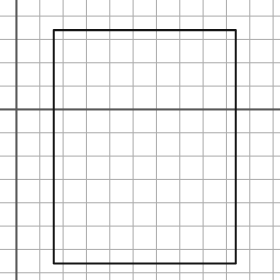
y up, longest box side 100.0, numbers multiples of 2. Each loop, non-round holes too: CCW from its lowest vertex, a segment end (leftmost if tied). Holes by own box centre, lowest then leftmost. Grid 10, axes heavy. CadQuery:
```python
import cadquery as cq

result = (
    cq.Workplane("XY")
    .moveTo(16.0, -66.0)
    .lineTo(94.0, -66.0)
    .lineTo(94.0, 34.0)
    .lineTo(16.0, 34.0)
    .close()
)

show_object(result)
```